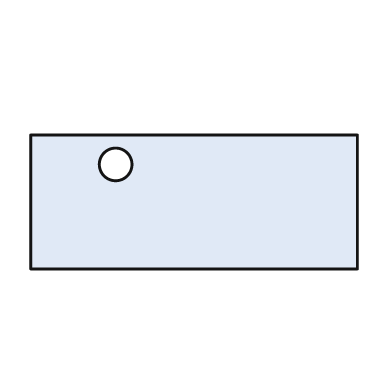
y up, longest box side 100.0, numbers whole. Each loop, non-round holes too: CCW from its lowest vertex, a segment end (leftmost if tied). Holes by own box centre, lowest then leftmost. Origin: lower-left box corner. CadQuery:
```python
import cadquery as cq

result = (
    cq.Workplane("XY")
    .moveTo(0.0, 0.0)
    .lineTo(100.0, 0.0)
    .lineTo(100.0, 41.0)
    .lineTo(0.0, 41.0)
    .close()
    .moveTo(26.0, 32.0)
    .circle(5.0)
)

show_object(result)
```